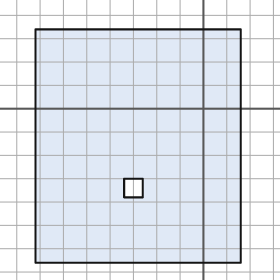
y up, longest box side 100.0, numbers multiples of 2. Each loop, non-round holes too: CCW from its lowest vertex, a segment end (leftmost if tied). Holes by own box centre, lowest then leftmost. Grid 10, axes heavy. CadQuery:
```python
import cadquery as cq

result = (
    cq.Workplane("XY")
    .moveTo(-72.0, -66.0)
    .lineTo(16.0, -66.0)
    .lineTo(16.0, 34.0)
    .lineTo(-72.0, 34.0)
    .close()
    .moveTo(-34.0, -38.0)
    .lineTo(-26.0, -38.0)
    .lineTo(-26.0, -30.0)
    .lineTo(-34.0, -30.0)
    .close()
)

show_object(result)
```